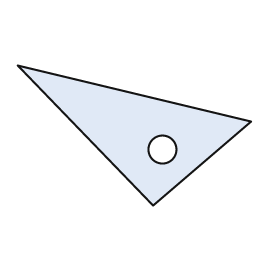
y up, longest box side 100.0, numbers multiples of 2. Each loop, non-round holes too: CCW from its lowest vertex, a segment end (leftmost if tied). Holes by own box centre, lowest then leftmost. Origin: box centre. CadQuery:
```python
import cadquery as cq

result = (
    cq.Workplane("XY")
    .moveTo(8.0, -30.0)
    .lineTo(50.0, 6.0)
    .lineTo(-50.0, 30.0)
    .close()
    .moveTo(12.0, -6.0)
    .circle(6.0)
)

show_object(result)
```